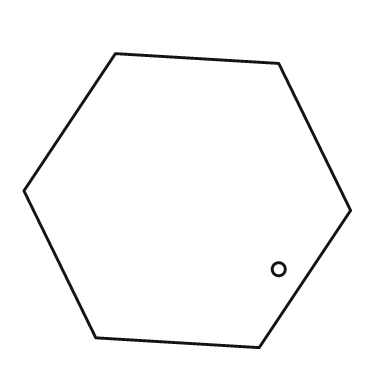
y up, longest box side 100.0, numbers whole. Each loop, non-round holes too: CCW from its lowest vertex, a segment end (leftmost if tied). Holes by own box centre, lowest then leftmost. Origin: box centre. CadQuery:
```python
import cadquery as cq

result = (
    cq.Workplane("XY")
    .moveTo(22.0, -45.0)
    .lineTo(50.0, -3.0)
    .lineTo(28.0, 42.0)
    .lineTo(-22.0, 45.0)
    .lineTo(-50.0, 3.0)
    .lineTo(-28.0, -42.0)
    .close()
    .moveTo(28.0, -21.0)
    .circle(2.0)
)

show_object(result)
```